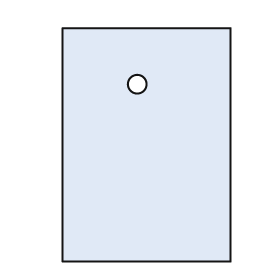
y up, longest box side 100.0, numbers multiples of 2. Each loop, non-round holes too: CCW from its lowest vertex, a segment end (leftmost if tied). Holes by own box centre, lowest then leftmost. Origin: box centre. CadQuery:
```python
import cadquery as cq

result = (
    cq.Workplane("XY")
    .moveTo(-36.0, -50.0)
    .lineTo(36.0, -50.0)
    .lineTo(36.0, 50.0)
    .lineTo(-36.0, 50.0)
    .close()
    .moveTo(-4.0, 26.0)
    .circle(4.0)
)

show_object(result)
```